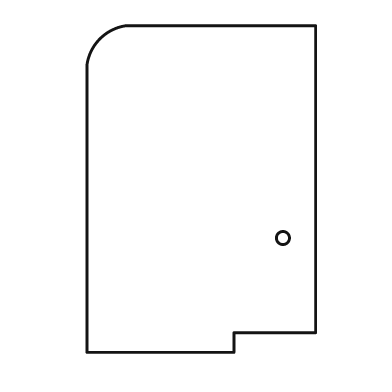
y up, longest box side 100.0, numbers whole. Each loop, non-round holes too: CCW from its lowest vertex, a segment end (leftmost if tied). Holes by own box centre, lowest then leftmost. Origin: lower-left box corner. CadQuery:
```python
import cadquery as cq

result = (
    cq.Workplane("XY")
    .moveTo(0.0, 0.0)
    .lineTo(45.0, 0.0)
    .lineTo(45.0, 6.0)
    .lineTo(70.0, 6.0)
    .lineTo(70.0, 100.0)
    .lineTo(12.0, 100.0)
    .threePointArc((4.0, 96.0), (0.0, 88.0))
    .close()
    .moveTo(60.0, 35.0)
    .circle(2.0)
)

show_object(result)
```